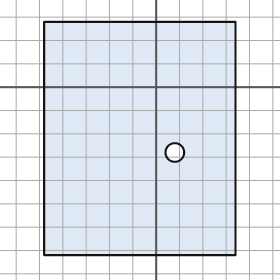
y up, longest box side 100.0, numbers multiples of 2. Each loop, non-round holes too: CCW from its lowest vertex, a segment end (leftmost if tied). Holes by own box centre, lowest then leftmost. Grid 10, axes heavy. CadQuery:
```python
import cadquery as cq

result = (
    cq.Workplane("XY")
    .moveTo(-48.0, -72.0)
    .lineTo(34.0, -72.0)
    .lineTo(34.0, 28.0)
    .lineTo(-48.0, 28.0)
    .close()
    .moveTo(8.0, -28.0)
    .circle(4.0)
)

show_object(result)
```